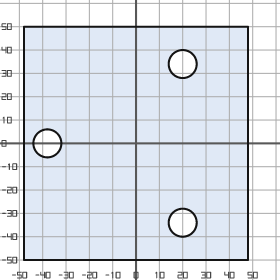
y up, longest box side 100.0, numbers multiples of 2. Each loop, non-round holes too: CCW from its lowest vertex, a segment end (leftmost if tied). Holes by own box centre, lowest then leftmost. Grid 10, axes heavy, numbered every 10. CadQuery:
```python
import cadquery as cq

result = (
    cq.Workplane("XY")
    .moveTo(-48.0, -50.0)
    .lineTo(48.0, -50.0)
    .lineTo(48.0, 50.0)
    .lineTo(-48.0, 50.0)
    .close()
    .moveTo(20.0, -34.0)
    .circle(6.0)
    .moveTo(-38.0, 0.0)
    .circle(6.0)
    .moveTo(20.0, 34.0)
    .circle(6.0)
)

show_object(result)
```